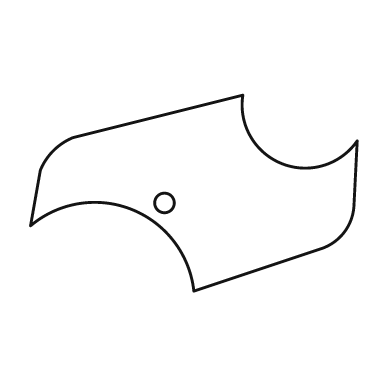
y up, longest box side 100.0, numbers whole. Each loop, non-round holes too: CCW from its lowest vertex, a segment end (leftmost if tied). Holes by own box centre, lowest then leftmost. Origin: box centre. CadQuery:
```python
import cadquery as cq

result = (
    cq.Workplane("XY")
    .moveTo(0.0, -30.0)
    .lineTo(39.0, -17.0)
    .threePointArc((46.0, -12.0), (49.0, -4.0))
    .lineTo(50.0, 16.0)
    .threePointArc((27.0, 9.0), (15.0, 30.0))
    .lineTo(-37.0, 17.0)
    .threePointArc((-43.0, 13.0), (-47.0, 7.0))
    .lineTo(-50.0, -10.0)
    .threePointArc((-19.0, -5.0), (0.0, -30.0))
    .close()
    .moveTo(-9.0, -3.0)
    .circle(3.0)
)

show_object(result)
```